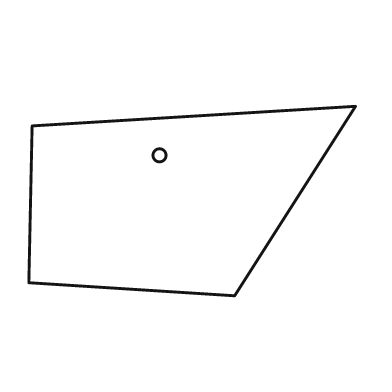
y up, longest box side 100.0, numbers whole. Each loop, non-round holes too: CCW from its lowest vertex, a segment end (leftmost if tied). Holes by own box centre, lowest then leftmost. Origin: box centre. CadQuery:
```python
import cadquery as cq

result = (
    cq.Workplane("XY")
    .moveTo(13.0, -29.0)
    .lineTo(50.0, 29.0)
    .lineTo(-49.0, 23.0)
    .lineTo(-50.0, -25.0)
    .close()
    .moveTo(-10.0, 14.0)
    .circle(2.0)
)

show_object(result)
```